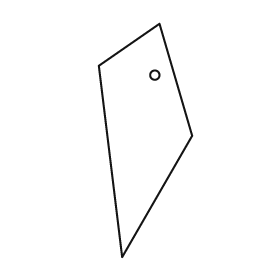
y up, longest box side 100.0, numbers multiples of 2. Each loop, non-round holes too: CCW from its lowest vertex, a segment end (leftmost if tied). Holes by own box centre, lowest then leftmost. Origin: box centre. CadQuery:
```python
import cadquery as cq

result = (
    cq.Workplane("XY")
    .moveTo(-10.0, -50.0)
    .lineTo(20.0, 2.0)
    .lineTo(6.0, 50.0)
    .lineTo(-20.0, 32.0)
    .close()
    .moveTo(4.0, 28.0)
    .circle(2.0)
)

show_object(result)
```